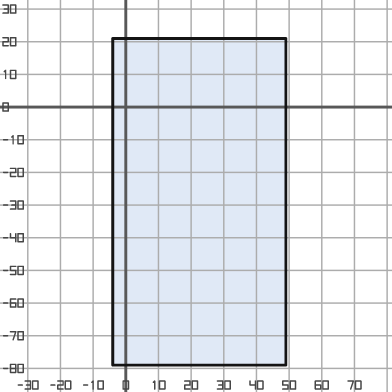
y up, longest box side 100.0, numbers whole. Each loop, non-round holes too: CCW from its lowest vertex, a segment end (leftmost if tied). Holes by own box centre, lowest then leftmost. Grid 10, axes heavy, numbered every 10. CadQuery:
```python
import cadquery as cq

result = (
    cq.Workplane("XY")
    .moveTo(-4.0, -79.0)
    .lineTo(49.0, -79.0)
    .lineTo(49.0, 21.0)
    .lineTo(-4.0, 21.0)
    .close()
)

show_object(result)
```